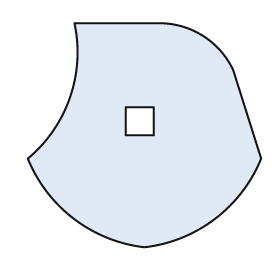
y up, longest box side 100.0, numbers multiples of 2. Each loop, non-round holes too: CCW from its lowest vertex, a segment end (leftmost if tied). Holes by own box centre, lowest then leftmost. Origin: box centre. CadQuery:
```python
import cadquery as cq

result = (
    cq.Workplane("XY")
    .moveTo(0.0, -48.0)
    .threePointArc((30.0, -36.0), (50.0, -10.0))
    .lineTo(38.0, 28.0)
    .threePointArc((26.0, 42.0), (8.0, 48.0))
    .lineTo(-30.0, 48.0)
    .threePointArc((-32.0, 16.0), (-50.0, -10.0))
    .threePointArc((-30.0, -36.0), (0.0, -48.0))
    .close()
    .moveTo(-8.0, 0.0)
    .lineTo(4.0, 0.0)
    .lineTo(4.0, 12.0)
    .lineTo(-8.0, 12.0)
    .close()
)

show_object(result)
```